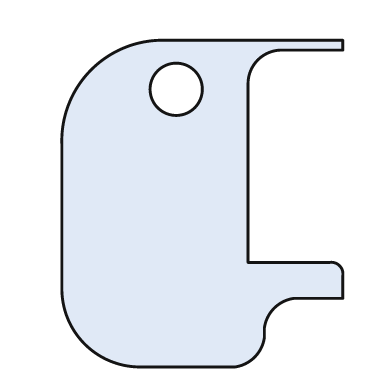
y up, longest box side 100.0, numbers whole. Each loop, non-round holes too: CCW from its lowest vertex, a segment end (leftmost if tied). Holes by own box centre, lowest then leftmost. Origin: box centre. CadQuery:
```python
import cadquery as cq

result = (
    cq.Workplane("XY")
    .moveTo(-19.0, -50.0)
    .lineTo(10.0, -50.0)
    .threePointArc((16.0, -47.0), (19.0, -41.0))
    .lineTo(19.0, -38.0)
    .threePointArc((22.0, -32.0), (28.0, -29.0))
    .lineTo(43.0, -29.0)
    .lineTo(43.0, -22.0)
    .threePointArc((42.0, -19.0), (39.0, -18.0))
    .lineTo(14.0, -18.0)
    .lineTo(14.0, 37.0)
    .threePointArc((17.0, 44.0), (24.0, 47.0))
    .lineTo(43.0, 47.0)
    .lineTo(43.0, 50.0)
    .lineTo(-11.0, 50.0)
    .threePointArc((-34.0, 41.0), (-43.0, 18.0))
    .lineTo(-43.0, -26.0)
    .threePointArc((-36.0, -43.0), (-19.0, -50.0))
    .close()
    .moveTo(-8.0, 35.0)
    .circle(8.0)
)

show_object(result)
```